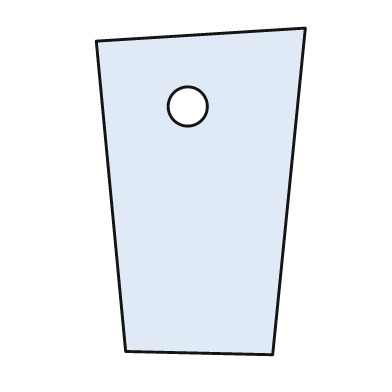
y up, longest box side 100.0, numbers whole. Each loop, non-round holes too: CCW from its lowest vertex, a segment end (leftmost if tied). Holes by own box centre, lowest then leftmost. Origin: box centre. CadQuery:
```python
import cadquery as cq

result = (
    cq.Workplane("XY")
    .moveTo(22.0, -50.0)
    .lineTo(32.0, 50.0)
    .lineTo(-32.0, 46.0)
    .lineTo(-23.0, -49.0)
    .close()
    .moveTo(-4.0, 26.0)
    .circle(6.0)
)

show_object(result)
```